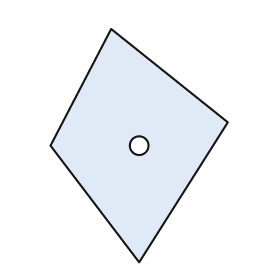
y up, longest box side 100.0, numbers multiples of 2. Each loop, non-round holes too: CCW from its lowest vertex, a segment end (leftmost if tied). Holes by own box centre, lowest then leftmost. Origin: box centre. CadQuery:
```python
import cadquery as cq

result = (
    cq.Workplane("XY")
    .moveTo(0.0, -50.0)
    .lineTo(38.0, 10.0)
    .lineTo(-12.0, 50.0)
    .lineTo(-38.0, 0.0)
    .close()
    .moveTo(0.0, 0.0)
    .circle(4.0)
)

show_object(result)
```